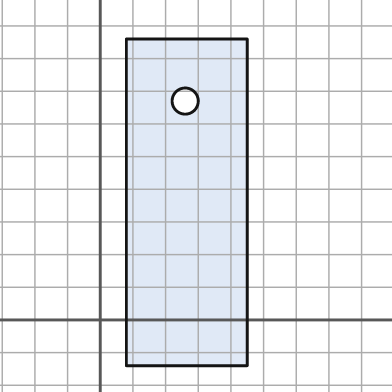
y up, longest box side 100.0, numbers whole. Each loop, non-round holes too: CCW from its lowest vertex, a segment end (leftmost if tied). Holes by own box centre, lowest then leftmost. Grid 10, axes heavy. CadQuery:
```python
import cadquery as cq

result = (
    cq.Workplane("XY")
    .moveTo(8.0, -14.0)
    .lineTo(45.0, -14.0)
    .lineTo(45.0, 86.0)
    .lineTo(8.0, 86.0)
    .close()
    .moveTo(26.0, 67.0)
    .circle(4.0)
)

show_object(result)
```